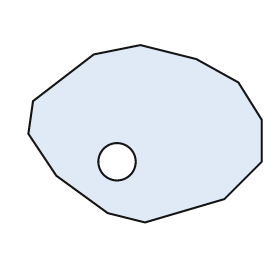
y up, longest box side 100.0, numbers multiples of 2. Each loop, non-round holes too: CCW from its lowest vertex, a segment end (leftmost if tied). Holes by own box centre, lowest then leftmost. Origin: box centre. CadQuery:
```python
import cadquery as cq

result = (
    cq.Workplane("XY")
    .moveTo(0.0, -38.0)
    .lineTo(34.0, -28.0)
    .lineTo(50.0, -12.0)
    .lineTo(50.0, 6.0)
    .lineTo(40.0, 22.0)
    .lineTo(22.0, 32.0)
    .lineTo(-2.0, 38.0)
    .lineTo(-22.0, 34.0)
    .lineTo(-48.0, 14.0)
    .lineTo(-50.0, 0.0)
    .lineTo(-38.0, -18.0)
    .lineTo(-16.0, -34.0)
    .close()
    .moveTo(-12.0, -12.0)
    .circle(8.0)
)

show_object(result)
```